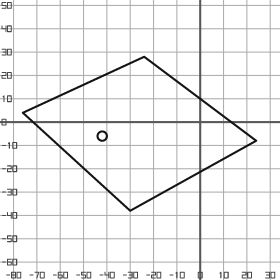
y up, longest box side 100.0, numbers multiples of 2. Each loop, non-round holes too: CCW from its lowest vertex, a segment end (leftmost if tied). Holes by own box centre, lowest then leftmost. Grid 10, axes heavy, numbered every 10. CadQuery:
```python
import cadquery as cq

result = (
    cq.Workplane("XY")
    .moveTo(-30.0, -38.0)
    .lineTo(24.0, -8.0)
    .lineTo(-24.0, 28.0)
    .lineTo(-76.0, 4.0)
    .close()
    .moveTo(-42.0, -6.0)
    .circle(2.0)
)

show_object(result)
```